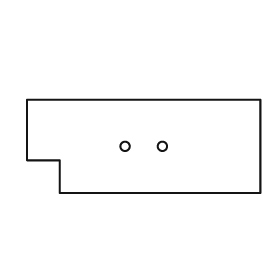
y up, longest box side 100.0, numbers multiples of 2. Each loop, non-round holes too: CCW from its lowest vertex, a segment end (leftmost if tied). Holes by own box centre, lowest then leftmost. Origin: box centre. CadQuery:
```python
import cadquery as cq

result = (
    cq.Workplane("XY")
    .moveTo(-36.0, -20.0)
    .lineTo(50.0, -20.0)
    .lineTo(50.0, 20.0)
    .lineTo(-50.0, 20.0)
    .lineTo(-50.0, -6.0)
    .lineTo(-36.0, -6.0)
    .close()
    .moveTo(-8.0, 0.0)
    .circle(2.0)
    .moveTo(8.0, 0.0)
    .circle(2.0)
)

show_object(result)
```